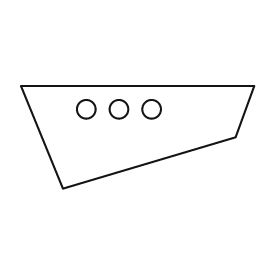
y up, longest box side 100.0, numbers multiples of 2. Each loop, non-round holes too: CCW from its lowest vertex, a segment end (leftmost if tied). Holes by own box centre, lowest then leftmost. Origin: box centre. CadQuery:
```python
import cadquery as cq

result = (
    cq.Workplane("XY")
    .moveTo(-32.0, -22.0)
    .lineTo(42.0, 0.0)
    .lineTo(50.0, 22.0)
    .lineTo(-50.0, 22.0)
    .close()
    .moveTo(-22.0, 12.0)
    .circle(4.0)
    .moveTo(-8.0, 12.0)
    .circle(4.0)
    .moveTo(6.0, 12.0)
    .circle(4.0)
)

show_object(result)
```